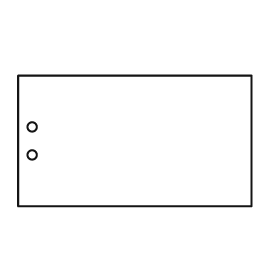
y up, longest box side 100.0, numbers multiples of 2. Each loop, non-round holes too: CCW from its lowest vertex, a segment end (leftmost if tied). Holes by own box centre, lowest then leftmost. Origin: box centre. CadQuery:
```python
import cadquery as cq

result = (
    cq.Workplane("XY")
    .moveTo(-50.0, -28.0)
    .lineTo(50.0, -28.0)
    .lineTo(50.0, 28.0)
    .lineTo(-50.0, 28.0)
    .close()
    .moveTo(-44.0, -6.0)
    .circle(2.0)
    .moveTo(-44.0, 6.0)
    .circle(2.0)
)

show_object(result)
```